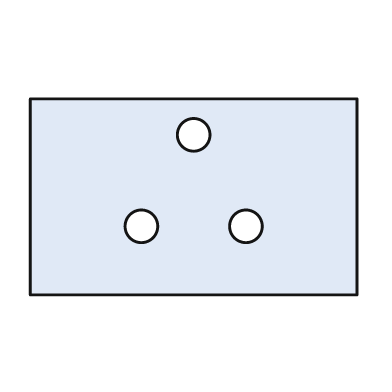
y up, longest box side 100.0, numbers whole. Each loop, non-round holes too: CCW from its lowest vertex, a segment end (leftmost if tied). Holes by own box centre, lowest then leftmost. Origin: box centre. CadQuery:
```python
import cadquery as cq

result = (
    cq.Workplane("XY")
    .moveTo(-50.0, -30.0)
    .lineTo(50.0, -30.0)
    .lineTo(50.0, 30.0)
    .lineTo(-50.0, 30.0)
    .close()
    .moveTo(-16.0, -9.0)
    .circle(5.0)
    .moveTo(16.0, -9.0)
    .circle(5.0)
    .moveTo(0.0, 19.0)
    .circle(5.0)
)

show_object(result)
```